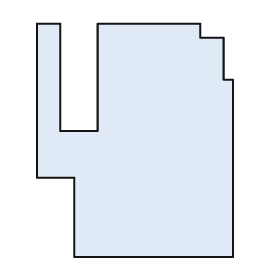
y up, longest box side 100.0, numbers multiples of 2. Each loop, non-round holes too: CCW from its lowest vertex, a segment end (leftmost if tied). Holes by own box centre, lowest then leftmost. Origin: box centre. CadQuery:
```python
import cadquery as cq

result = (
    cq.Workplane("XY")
    .moveTo(-26.0, -50.0)
    .lineTo(42.0, -50.0)
    .lineTo(42.0, 26.0)
    .lineTo(38.0, 26.0)
    .lineTo(38.0, 44.0)
    .lineTo(28.0, 44.0)
    .lineTo(28.0, 50.0)
    .lineTo(-16.0, 50.0)
    .lineTo(-16.0, 4.0)
    .lineTo(-32.0, 4.0)
    .lineTo(-32.0, 50.0)
    .lineTo(-42.0, 50.0)
    .lineTo(-42.0, -16.0)
    .lineTo(-26.0, -16.0)
    .close()
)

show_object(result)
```